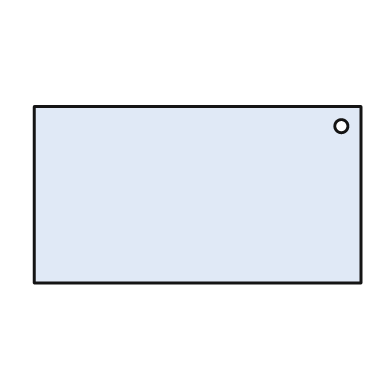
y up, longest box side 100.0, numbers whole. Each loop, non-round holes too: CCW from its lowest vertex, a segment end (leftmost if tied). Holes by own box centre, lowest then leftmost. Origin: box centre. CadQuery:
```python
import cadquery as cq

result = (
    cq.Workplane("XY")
    .moveTo(-50.0, -27.0)
    .lineTo(50.0, -27.0)
    .lineTo(50.0, 27.0)
    .lineTo(-50.0, 27.0)
    .close()
    .moveTo(44.0, 21.0)
    .circle(2.0)
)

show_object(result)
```